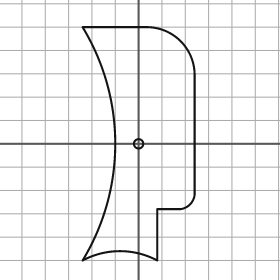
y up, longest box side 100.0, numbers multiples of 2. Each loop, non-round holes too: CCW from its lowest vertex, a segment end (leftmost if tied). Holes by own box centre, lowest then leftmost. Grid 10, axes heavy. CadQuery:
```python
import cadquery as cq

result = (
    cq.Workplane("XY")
    .moveTo(-24.0, -50.0)
    .threePointArc((-8.0, -46.0), (8.0, -50.0))
    .lineTo(8.0, -28.0)
    .lineTo(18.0, -28.0)
    .threePointArc((22.0, -26.0), (24.0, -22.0))
    .lineTo(24.0, 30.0)
    .threePointArc((18.0, 44.0), (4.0, 50.0))
    .lineTo(-24.0, 50.0)
    .threePointArc((-10.0, 0.0), (-24.0, -50.0))
    .close()
    .moveTo(0.0, 0.0)
    .circle(2.0)
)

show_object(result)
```